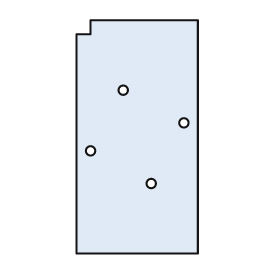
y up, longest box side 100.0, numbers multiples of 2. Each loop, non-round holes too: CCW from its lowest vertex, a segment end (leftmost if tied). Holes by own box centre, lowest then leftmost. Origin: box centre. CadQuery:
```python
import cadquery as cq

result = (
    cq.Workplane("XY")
    .moveTo(-26.0, -50.0)
    .lineTo(26.0, -50.0)
    .lineTo(26.0, 50.0)
    .lineTo(-20.0, 50.0)
    .lineTo(-20.0, 44.0)
    .lineTo(-26.0, 44.0)
    .close()
    .moveTo(6.0, -20.0)
    .circle(2.0)
    .moveTo(-20.0, -6.0)
    .circle(2.0)
    .moveTo(20.0, 6.0)
    .circle(2.0)
    .moveTo(-6.0, 20.0)
    .circle(2.0)
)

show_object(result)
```